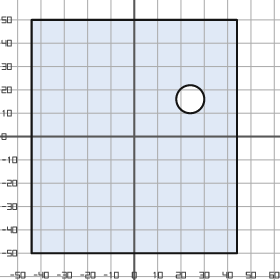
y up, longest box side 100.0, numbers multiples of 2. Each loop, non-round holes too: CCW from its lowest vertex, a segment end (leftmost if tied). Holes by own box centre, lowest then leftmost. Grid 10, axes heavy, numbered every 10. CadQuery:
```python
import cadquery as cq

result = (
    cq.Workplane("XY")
    .moveTo(-44.0, -50.0)
    .lineTo(44.0, -50.0)
    .lineTo(44.0, 50.0)
    .lineTo(-44.0, 50.0)
    .close()
    .moveTo(24.0, 16.0)
    .circle(6.0)
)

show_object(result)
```